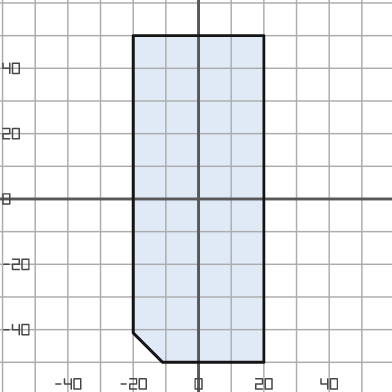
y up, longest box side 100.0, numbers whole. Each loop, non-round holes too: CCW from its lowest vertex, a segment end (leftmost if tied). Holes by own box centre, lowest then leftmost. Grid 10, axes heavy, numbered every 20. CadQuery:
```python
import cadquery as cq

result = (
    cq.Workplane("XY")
    .moveTo(-11.0, -50.0)
    .lineTo(20.0, -50.0)
    .lineTo(20.0, 50.0)
    .lineTo(-20.0, 50.0)
    .lineTo(-20.0, -41.0)
    .close()
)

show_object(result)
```